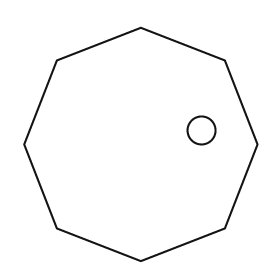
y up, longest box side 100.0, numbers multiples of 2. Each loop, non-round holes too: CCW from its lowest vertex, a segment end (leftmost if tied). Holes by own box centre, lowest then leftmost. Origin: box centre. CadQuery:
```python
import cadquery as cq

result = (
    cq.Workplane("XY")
    .moveTo(0.0, -50.0)
    .lineTo(36.0, -36.0)
    .lineTo(50.0, 0.0)
    .lineTo(36.0, 36.0)
    .lineTo(0.0, 50.0)
    .lineTo(-36.0, 36.0)
    .lineTo(-50.0, 0.0)
    .lineTo(-36.0, -36.0)
    .close()
    .moveTo(26.0, 6.0)
    .circle(6.0)
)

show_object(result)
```